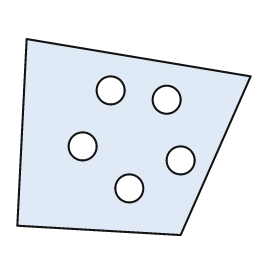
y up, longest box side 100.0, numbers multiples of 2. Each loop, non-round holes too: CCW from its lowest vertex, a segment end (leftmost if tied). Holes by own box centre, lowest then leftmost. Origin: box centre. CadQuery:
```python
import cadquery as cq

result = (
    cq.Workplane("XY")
    .moveTo(20.0, -42.0)
    .lineTo(50.0, 26.0)
    .lineTo(-46.0, 42.0)
    .lineTo(-50.0, -38.0)
    .close()
    .moveTo(-2.0, -22.0)
    .circle(6.0)
    .moveTo(20.0, -10.0)
    .circle(6.0)
    .moveTo(-22.0, -4.0)
    .circle(6.0)
    .moveTo(14.0, 16.0)
    .circle(6.0)
    .moveTo(-10.0, 20.0)
    .circle(6.0)
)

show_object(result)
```